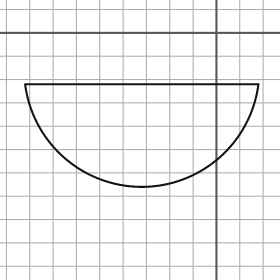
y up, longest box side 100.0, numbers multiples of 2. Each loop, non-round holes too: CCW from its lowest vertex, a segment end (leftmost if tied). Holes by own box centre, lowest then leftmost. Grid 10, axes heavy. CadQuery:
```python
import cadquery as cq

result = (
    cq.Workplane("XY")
    .moveTo(-82.0, -22.0)
    .threePointArc((-32.0, -66.0), (18.0, -22.0))
    .close()
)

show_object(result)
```